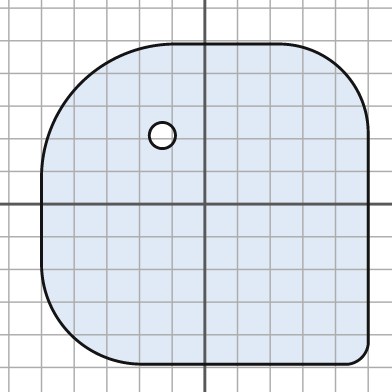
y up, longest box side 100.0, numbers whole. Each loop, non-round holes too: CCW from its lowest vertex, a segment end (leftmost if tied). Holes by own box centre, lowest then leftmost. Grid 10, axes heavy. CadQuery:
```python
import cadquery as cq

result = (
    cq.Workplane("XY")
    .moveTo(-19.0, -49.0)
    .lineTo(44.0, -49.0)
    .threePointArc((48.0, -47.0), (50.0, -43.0))
    .lineTo(50.0, 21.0)
    .threePointArc((42.0, 41.0), (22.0, 49.0))
    .lineTo(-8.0, 49.0)
    .threePointArc((-38.0, 37.0), (-50.0, 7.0))
    .lineTo(-50.0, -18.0)
    .threePointArc((-41.0, -40.0), (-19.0, -49.0))
    .close()
    .moveTo(-13.0, 21.0)
    .circle(4.0)
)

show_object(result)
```